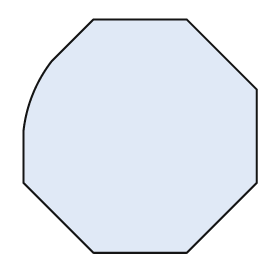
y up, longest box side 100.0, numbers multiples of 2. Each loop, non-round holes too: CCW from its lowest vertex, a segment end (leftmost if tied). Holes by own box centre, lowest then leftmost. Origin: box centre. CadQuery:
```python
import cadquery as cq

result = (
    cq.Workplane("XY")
    .moveTo(-20.0, -50.0)
    .lineTo(20.0, -50.0)
    .lineTo(50.0, -20.0)
    .lineTo(50.0, 20.0)
    .lineTo(20.0, 50.0)
    .lineTo(-20.0, 50.0)
    .lineTo(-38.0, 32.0)
    .threePointArc((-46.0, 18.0), (-50.0, 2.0))
    .lineTo(-50.0, -20.0)
    .close()
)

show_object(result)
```